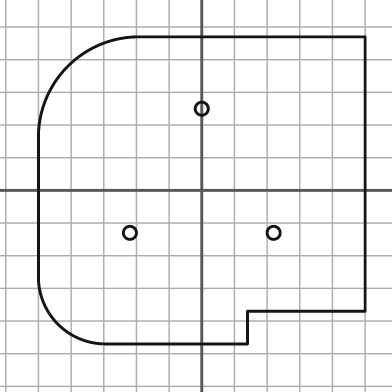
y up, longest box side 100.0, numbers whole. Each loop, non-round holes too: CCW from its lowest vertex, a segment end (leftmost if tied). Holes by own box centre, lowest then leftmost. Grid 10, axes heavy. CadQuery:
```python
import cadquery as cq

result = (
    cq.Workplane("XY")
    .moveTo(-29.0, -47.0)
    .lineTo(14.0, -47.0)
    .lineTo(14.0, -37.0)
    .lineTo(50.0, -37.0)
    .lineTo(50.0, 47.0)
    .lineTo(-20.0, 47.0)
    .threePointArc((-41.0, 38.0), (-50.0, 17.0))
    .lineTo(-50.0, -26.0)
    .threePointArc((-44.0, -41.0), (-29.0, -47.0))
    .close()
    .moveTo(-22.0, -13.0)
    .circle(2.0)
    .moveTo(22.0, -13.0)
    .circle(2.0)
    .moveTo(0.0, 25.0)
    .circle(2.0)
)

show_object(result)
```